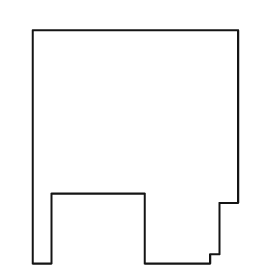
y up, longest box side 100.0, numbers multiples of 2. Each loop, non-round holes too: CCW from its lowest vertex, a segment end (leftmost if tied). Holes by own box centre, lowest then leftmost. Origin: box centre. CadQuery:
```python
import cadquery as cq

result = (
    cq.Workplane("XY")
    .moveTo(-44.0, -50.0)
    .lineTo(-36.0, -50.0)
    .lineTo(-36.0, -20.0)
    .lineTo(4.0, -20.0)
    .lineTo(4.0, -50.0)
    .lineTo(32.0, -50.0)
    .lineTo(32.0, -46.0)
    .lineTo(36.0, -46.0)
    .lineTo(36.0, -24.0)
    .lineTo(44.0, -24.0)
    .lineTo(44.0, 50.0)
    .lineTo(-44.0, 50.0)
    .close()
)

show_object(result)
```